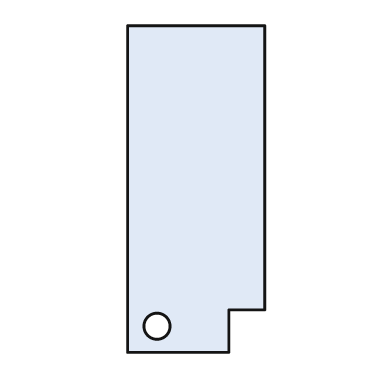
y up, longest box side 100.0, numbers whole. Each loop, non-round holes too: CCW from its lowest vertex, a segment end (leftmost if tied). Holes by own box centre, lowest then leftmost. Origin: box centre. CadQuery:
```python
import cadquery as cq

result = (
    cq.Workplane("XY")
    .moveTo(-21.0, -50.0)
    .lineTo(10.0, -50.0)
    .lineTo(10.0, -37.0)
    .lineTo(21.0, -37.0)
    .lineTo(21.0, 50.0)
    .lineTo(-21.0, 50.0)
    .close()
    .moveTo(-12.0, -42.0)
    .circle(4.0)
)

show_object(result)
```